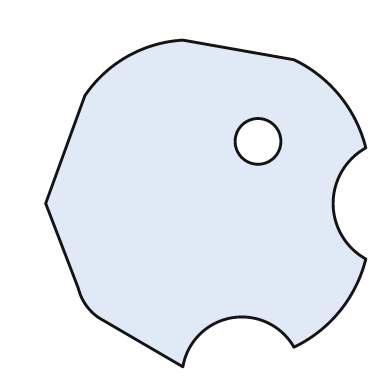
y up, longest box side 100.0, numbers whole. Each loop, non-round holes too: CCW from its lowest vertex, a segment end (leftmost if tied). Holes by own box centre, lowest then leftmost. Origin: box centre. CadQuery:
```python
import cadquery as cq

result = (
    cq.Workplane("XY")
    .moveTo(-7.0, -50.0)
    .threePointArc((8.0, -35.0), (27.0, -44.0))
    .threePointArc((41.0, -33.0), (49.0, -17.0))
    .threePointArc((39.0, 0.0), (49.0, 17.0))
    .threePointArc((41.0, 33.0), (27.0, 44.0))
    .lineTo(-7.0, 50.0)
    .threePointArc((-24.0, 45.0), (-37.0, 33.0))
    .lineTo(-49.0, 0.0)
    .lineTo(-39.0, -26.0)
    .threePointArc((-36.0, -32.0), (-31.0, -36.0))
    .close()
    .moveTo(16.0, 19.0)
    .circle(7.0)
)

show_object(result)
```